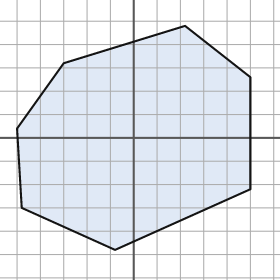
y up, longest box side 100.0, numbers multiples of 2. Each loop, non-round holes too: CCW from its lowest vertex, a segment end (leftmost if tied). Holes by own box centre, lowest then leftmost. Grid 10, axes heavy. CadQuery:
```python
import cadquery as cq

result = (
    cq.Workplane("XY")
    .moveTo(-8.0, -48.0)
    .lineTo(50.0, -22.0)
    .lineTo(50.0, 26.0)
    .lineTo(22.0, 48.0)
    .lineTo(-30.0, 32.0)
    .lineTo(-50.0, 4.0)
    .lineTo(-48.0, -30.0)
    .close()
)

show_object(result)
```